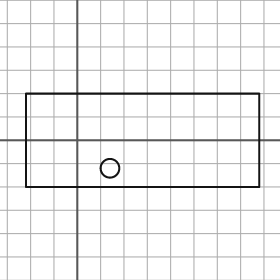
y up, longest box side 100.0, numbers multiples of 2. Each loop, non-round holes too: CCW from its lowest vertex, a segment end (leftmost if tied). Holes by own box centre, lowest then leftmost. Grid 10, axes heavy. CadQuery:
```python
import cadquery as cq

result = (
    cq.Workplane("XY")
    .moveTo(-22.0, -20.0)
    .lineTo(78.0, -20.0)
    .lineTo(78.0, 20.0)
    .lineTo(-22.0, 20.0)
    .close()
    .moveTo(14.0, -12.0)
    .circle(4.0)
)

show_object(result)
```